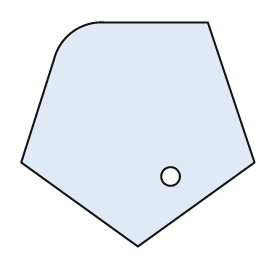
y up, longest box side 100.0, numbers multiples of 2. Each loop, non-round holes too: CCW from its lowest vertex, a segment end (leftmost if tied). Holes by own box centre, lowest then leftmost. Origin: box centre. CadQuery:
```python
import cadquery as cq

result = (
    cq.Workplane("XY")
    .moveTo(0.0, -48.0)
    .lineTo(50.0, -12.0)
    .lineTo(30.0, 48.0)
    .lineTo(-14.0, 48.0)
    .threePointArc((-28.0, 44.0), (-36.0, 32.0))
    .lineTo(-50.0, -12.0)
    .close()
    .moveTo(14.0, -18.0)
    .circle(4.0)
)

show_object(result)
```